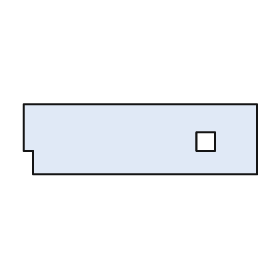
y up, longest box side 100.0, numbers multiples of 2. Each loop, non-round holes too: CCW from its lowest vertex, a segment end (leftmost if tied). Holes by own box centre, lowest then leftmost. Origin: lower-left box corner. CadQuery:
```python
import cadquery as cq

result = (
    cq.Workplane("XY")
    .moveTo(4.0, 0.0)
    .lineTo(100.0, 0.0)
    .lineTo(100.0, 30.0)
    .lineTo(0.0, 30.0)
    .lineTo(0.0, 10.0)
    .lineTo(4.0, 10.0)
    .close()
    .moveTo(74.0, 10.0)
    .lineTo(82.0, 10.0)
    .lineTo(82.0, 18.0)
    .lineTo(74.0, 18.0)
    .close()
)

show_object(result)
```